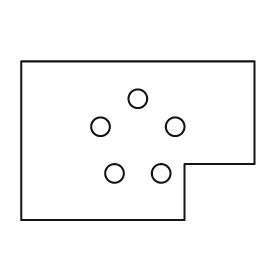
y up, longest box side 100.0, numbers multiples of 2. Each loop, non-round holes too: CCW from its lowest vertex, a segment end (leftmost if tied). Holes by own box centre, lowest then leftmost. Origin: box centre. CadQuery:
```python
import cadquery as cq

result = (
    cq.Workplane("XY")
    .moveTo(-50.0, -34.0)
    .lineTo(20.0, -34.0)
    .lineTo(20.0, -10.0)
    .lineTo(50.0, -10.0)
    .lineTo(50.0, 34.0)
    .lineTo(-50.0, 34.0)
    .close()
    .moveTo(-10.0, -14.0)
    .circle(4.0)
    .moveTo(10.0, -14.0)
    .circle(4.0)
    .moveTo(-16.0, 6.0)
    .circle(4.0)
    .moveTo(16.0, 6.0)
    .circle(4.0)
    .moveTo(0.0, 18.0)
    .circle(4.0)
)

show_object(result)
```